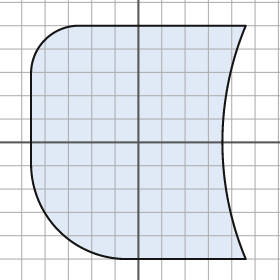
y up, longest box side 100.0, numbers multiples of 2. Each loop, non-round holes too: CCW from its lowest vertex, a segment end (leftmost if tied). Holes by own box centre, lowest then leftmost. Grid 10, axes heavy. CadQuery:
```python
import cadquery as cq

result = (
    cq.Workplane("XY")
    .moveTo(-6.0, -50.0)
    .lineTo(46.0, -50.0)
    .threePointArc((36.0, 0.0), (46.0, 50.0))
    .lineTo(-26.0, 50.0)
    .threePointArc((-40.0, 44.0), (-46.0, 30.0))
    .lineTo(-46.0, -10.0)
    .threePointArc((-34.0, -38.0), (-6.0, -50.0))
    .close()
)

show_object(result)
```